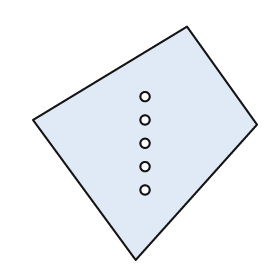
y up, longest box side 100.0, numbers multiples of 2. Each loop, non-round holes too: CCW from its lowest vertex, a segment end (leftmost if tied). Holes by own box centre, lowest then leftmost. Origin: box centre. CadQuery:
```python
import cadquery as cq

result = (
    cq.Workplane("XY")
    .moveTo(-4.0, -50.0)
    .lineTo(48.0, 8.0)
    .lineTo(18.0, 50.0)
    .lineTo(-48.0, 10.0)
    .close()
    .moveTo(0.0, -20.0)
    .circle(2.0)
    .moveTo(0.0, -10.0)
    .circle(2.0)
    .moveTo(0.0, 0.0)
    .circle(2.0)
    .moveTo(0.0, 10.0)
    .circle(2.0)
    .moveTo(0.0, 20.0)
    .circle(2.0)
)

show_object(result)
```